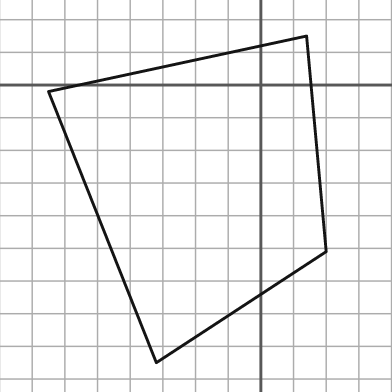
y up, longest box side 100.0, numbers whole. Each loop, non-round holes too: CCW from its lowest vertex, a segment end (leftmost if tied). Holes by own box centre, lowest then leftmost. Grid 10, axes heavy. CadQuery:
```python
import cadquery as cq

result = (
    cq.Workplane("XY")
    .moveTo(-32.0, -85.0)
    .lineTo(20.0, -51.0)
    .lineTo(14.0, 15.0)
    .lineTo(-65.0, -2.0)
    .close()
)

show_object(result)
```